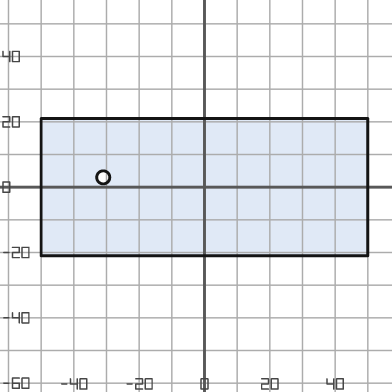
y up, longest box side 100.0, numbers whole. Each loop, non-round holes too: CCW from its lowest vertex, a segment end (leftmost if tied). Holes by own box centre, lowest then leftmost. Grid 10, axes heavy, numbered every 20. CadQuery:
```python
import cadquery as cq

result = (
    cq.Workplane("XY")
    .moveTo(-50.0, -21.0)
    .lineTo(50.0, -21.0)
    .lineTo(50.0, 21.0)
    .lineTo(-50.0, 21.0)
    .close()
    .moveTo(-31.0, 3.0)
    .circle(2.0)
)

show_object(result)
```